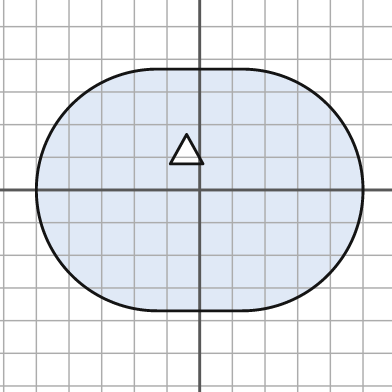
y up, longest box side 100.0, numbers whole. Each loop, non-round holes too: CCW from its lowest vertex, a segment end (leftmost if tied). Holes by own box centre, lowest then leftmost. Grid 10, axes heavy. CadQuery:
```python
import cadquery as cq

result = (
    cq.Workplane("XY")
    .moveTo(-13.0, -37.0)
    .lineTo(13.0, -37.0)
    .threePointArc((50.0, 0.0), (13.0, 37.0))
    .lineTo(-13.0, 37.0)
    .threePointArc((-50.0, 0.0), (-13.0, -37.0))
    .close()
    .moveTo(-9.0, 8.0)
    .lineTo(1.0, 8.0)
    .lineTo(-4.0, 17.0)
    .close()
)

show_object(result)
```